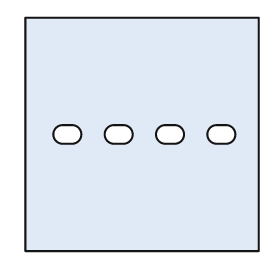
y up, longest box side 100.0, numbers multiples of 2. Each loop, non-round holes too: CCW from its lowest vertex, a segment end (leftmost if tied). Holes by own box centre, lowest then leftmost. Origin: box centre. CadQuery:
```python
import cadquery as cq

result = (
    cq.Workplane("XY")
    .moveTo(-50.0, -50.0)
    .lineTo(50.0, -50.0)
    .lineTo(50.0, 50.0)
    .lineTo(-50.0, 50.0)
    .close()
    .moveTo(-34.0, -4.0)
    .lineTo(-30.0, -4.0)
    .threePointArc((-26.0, 0.0), (-30.0, 4.0))
    .lineTo(-34.0, 4.0)
    .threePointArc((-38.0, 0.0), (-34.0, -4.0))
    .close()
    .moveTo(-12.0, -4.0)
    .lineTo(-8.0, -4.0)
    .threePointArc((-4.0, 0.0), (-8.0, 4.0))
    .lineTo(-12.0, 4.0)
    .threePointArc((-16.0, 0.0), (-12.0, -4.0))
    .close()
    .moveTo(10.0, -4.0)
    .lineTo(14.0, -4.0)
    .threePointArc((18.0, 0.0), (14.0, 4.0))
    .lineTo(10.0, 4.0)
    .threePointArc((6.0, 0.0), (10.0, -4.0))
    .close()
    .moveTo(32.0, -4.0)
    .lineTo(36.0, -4.0)
    .threePointArc((40.0, 0.0), (36.0, 4.0))
    .lineTo(32.0, 4.0)
    .threePointArc((28.0, 0.0), (32.0, -4.0))
    .close()
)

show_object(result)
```